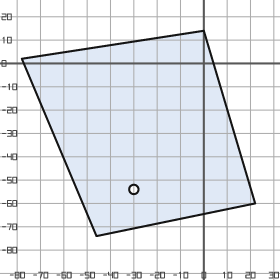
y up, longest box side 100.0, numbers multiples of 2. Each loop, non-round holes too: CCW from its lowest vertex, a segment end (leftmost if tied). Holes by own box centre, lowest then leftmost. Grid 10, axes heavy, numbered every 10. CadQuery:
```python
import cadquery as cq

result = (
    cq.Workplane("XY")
    .moveTo(-46.0, -74.0)
    .lineTo(22.0, -60.0)
    .lineTo(0.0, 14.0)
    .lineTo(-78.0, 2.0)
    .close()
    .moveTo(-30.0, -54.0)
    .circle(2.0)
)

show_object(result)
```